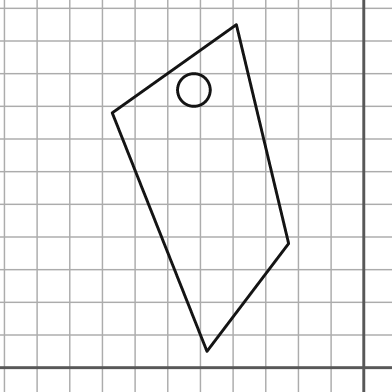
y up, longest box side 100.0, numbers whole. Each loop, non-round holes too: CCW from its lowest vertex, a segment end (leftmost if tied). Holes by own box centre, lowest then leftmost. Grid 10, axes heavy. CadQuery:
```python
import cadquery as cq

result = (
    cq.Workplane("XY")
    .moveTo(-48.0, 5.0)
    .lineTo(-23.0, 38.0)
    .lineTo(-39.0, 105.0)
    .lineTo(-77.0, 78.0)
    .close()
    .moveTo(-52.0, 85.0)
    .circle(5.0)
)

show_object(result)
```